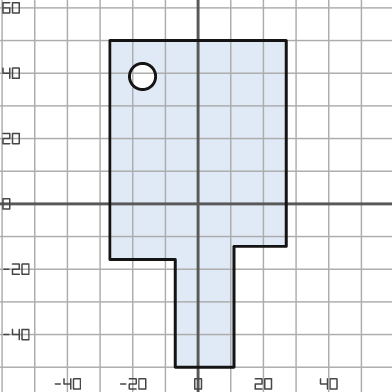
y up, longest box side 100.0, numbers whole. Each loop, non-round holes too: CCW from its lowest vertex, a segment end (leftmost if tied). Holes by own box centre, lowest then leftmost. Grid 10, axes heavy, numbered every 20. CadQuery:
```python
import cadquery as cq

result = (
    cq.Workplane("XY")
    .moveTo(-7.0, -50.0)
    .lineTo(11.0, -50.0)
    .lineTo(11.0, -13.0)
    .lineTo(27.0, -13.0)
    .lineTo(27.0, 50.0)
    .lineTo(-27.0, 50.0)
    .lineTo(-27.0, -17.0)
    .lineTo(-7.0, -17.0)
    .close()
    .moveTo(-17.0, 39.0)
    .circle(4.0)
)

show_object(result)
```